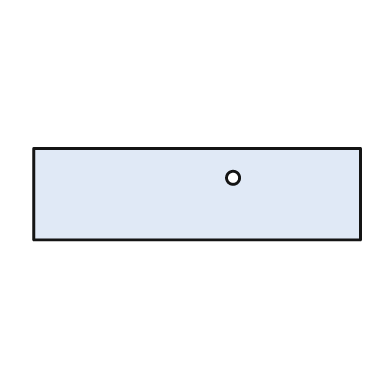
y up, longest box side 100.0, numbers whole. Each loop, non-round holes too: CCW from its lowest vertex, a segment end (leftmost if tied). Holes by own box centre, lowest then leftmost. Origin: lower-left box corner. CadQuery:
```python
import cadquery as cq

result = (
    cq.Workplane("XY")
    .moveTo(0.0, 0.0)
    .lineTo(100.0, 0.0)
    .lineTo(100.0, 28.0)
    .lineTo(0.0, 28.0)
    .close()
    .moveTo(61.0, 19.0)
    .circle(2.0)
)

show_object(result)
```